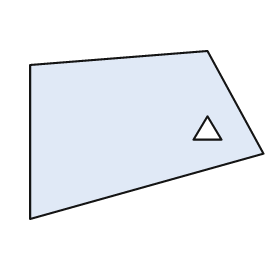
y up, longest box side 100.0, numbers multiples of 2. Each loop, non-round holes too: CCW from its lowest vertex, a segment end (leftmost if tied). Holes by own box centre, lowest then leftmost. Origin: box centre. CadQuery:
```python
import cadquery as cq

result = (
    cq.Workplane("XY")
    .moveTo(-50.0, -36.0)
    .lineTo(50.0, -8.0)
    .lineTo(26.0, 36.0)
    .lineTo(-50.0, 30.0)
    .close()
    .moveTo(20.0, -2.0)
    .lineTo(32.0, -2.0)
    .lineTo(26.0, 8.0)
    .close()
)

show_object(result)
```